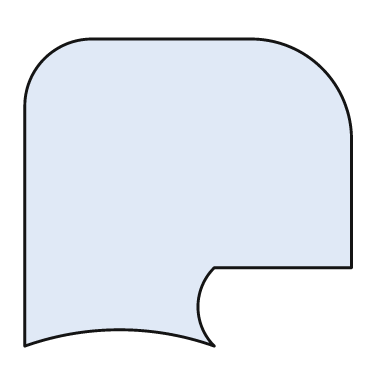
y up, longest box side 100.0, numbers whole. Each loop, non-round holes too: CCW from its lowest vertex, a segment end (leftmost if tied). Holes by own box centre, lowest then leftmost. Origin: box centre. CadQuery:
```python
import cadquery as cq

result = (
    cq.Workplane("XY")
    .moveTo(-50.0, -47.0)
    .threePointArc((-21.0, -42.0), (8.0, -47.0))
    .threePointArc((3.0, -35.0), (8.0, -23.0))
    .lineTo(50.0, -23.0)
    .lineTo(50.0, 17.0)
    .threePointArc((41.0, 38.0), (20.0, 47.0))
    .lineTo(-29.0, 47.0)
    .threePointArc((-44.0, 41.0), (-50.0, 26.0))
    .close()
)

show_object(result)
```